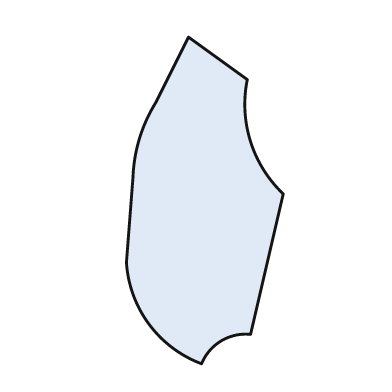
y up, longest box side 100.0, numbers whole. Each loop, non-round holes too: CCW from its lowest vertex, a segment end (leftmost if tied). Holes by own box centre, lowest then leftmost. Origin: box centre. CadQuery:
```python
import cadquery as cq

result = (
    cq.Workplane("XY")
    .moveTo(-1.0, -50.0)
    .threePointArc((5.0, -43.0), (14.0, -41.0))
    .lineTo(24.0, 2.0)
    .threePointArc((14.0, 18.0), (13.0, 37.0))
    .lineTo(-5.0, 50.0)
    .lineTo(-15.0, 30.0)
    .threePointArc((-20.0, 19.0), (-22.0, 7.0))
    .lineTo(-24.0, -19.0)
    .threePointArc((-17.0, -38.0), (-1.0, -50.0))
    .close()
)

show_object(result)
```